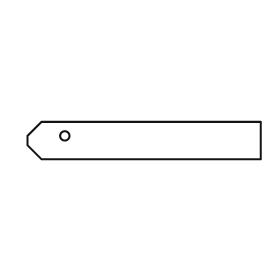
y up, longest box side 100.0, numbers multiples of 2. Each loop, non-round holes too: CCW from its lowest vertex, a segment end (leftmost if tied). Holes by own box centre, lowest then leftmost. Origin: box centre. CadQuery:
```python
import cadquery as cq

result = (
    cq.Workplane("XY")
    .moveTo(-44.0, -8.0)
    .lineTo(50.0, -8.0)
    .lineTo(50.0, 8.0)
    .lineTo(-44.0, 8.0)
    .lineTo(-50.0, 2.0)
    .lineTo(-50.0, -2.0)
    .close()
    .moveTo(-34.0, 2.0)
    .circle(2.0)
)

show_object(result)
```